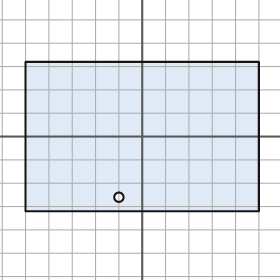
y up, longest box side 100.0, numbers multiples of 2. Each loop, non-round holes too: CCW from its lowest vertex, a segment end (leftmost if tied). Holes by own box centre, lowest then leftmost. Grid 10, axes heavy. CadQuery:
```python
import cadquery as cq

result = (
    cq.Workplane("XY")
    .moveTo(-50.0, -32.0)
    .lineTo(50.0, -32.0)
    .lineTo(50.0, 32.0)
    .lineTo(-50.0, 32.0)
    .close()
    .moveTo(-10.0, -26.0)
    .circle(2.0)
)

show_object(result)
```